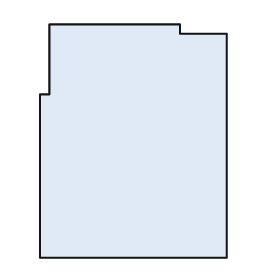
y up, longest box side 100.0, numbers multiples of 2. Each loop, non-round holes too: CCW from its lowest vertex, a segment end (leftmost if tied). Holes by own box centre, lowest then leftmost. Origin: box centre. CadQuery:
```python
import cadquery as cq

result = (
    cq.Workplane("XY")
    .moveTo(-40.0, -50.0)
    .lineTo(40.0, -50.0)
    .lineTo(40.0, 46.0)
    .lineTo(20.0, 46.0)
    .lineTo(20.0, 50.0)
    .lineTo(-36.0, 50.0)
    .lineTo(-36.0, 20.0)
    .lineTo(-40.0, 20.0)
    .close()
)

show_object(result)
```